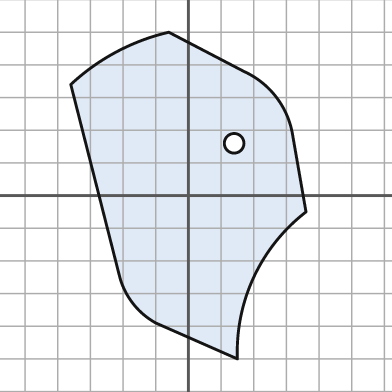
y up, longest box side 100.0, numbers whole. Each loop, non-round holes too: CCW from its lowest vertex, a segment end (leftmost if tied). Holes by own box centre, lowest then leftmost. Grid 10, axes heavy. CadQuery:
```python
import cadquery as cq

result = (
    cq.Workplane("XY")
    .moveTo(15.0, -50.0)
    .threePointArc((20.0, -25.0), (36.0, -5.0))
    .lineTo(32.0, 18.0)
    .threePointArc((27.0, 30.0), (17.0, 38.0))
    .lineTo(-6.0, 50.0)
    .threePointArc((-22.0, 44.0), (-36.0, 34.0))
    .lineTo(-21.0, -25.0)
    .threePointArc((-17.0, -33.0), (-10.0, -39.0))
    .close()
    .moveTo(14.0, 16.0)
    .circle(3.0)
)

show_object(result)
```